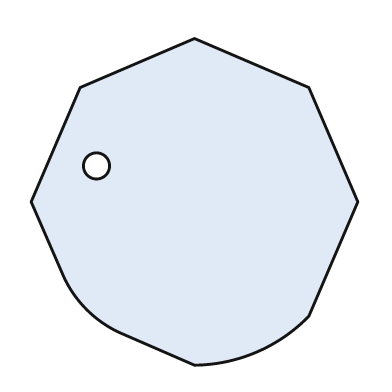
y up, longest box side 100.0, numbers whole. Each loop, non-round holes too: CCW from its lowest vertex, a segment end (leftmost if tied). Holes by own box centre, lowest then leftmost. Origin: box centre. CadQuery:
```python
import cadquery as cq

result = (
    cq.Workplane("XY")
    .moveTo(0.0, -50.0)
    .threePointArc((19.0, -46.0), (35.0, -35.0))
    .lineTo(50.0, 0.0)
    .lineTo(35.0, 35.0)
    .lineTo(0.0, 50.0)
    .lineTo(-35.0, 35.0)
    .lineTo(-50.0, 0.0)
    .lineTo(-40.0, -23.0)
    .threePointArc((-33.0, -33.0), (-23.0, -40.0))
    .close()
    .moveTo(-30.0, 11.0)
    .circle(4.0)
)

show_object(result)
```